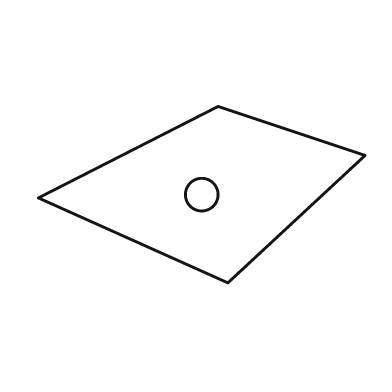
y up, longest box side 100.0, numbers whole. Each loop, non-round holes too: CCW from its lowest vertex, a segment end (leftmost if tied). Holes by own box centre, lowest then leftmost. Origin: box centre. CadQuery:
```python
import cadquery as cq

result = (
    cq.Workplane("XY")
    .moveTo(8.0, -27.0)
    .lineTo(50.0, 12.0)
    .lineTo(5.0, 27.0)
    .lineTo(-50.0, -1.0)
    .close()
    .moveTo(0.0, 0.0)
    .circle(5.0)
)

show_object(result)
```